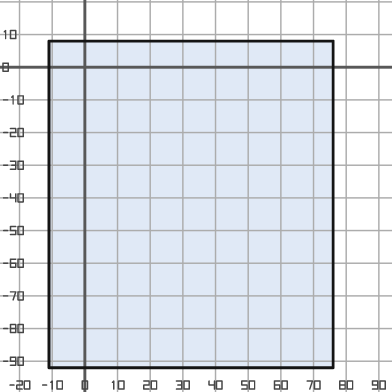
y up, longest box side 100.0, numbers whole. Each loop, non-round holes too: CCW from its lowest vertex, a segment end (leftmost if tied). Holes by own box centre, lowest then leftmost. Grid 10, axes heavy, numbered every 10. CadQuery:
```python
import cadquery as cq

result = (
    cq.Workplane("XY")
    .moveTo(-11.0, -92.0)
    .lineTo(76.0, -92.0)
    .lineTo(76.0, 8.0)
    .lineTo(-11.0, 8.0)
    .close()
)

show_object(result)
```